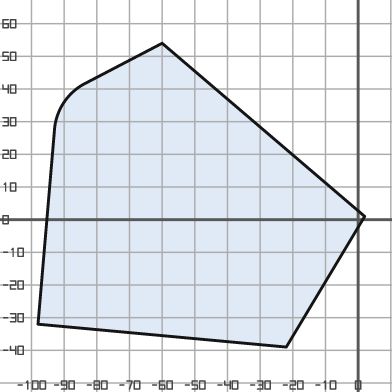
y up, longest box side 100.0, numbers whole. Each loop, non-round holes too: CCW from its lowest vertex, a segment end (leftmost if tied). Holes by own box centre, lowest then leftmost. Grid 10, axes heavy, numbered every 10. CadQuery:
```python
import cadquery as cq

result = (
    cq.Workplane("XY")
    .moveTo(-22.0, -39.0)
    .lineTo(2.0, 1.0)
    .lineTo(-60.0, 54.0)
    .lineTo(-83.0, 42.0)
    .threePointArc((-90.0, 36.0), (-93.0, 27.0))
    .lineTo(-98.0, -32.0)
    .close()
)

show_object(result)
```